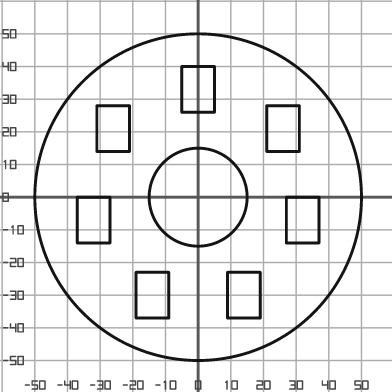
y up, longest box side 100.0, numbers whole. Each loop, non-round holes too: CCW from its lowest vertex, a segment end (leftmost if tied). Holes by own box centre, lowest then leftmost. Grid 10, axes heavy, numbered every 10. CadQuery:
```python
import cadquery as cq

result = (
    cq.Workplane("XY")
    .moveTo(0.0, 0.0)
    .circle(50.0)
    .moveTo(-19.0, -37.0)
    .lineTo(-9.0, -37.0)
    .lineTo(-9.0, -23.0)
    .lineTo(-19.0, -23.0)
    .close()
    .moveTo(9.0, -37.0)
    .lineTo(19.0, -37.0)
    .lineTo(19.0, -23.0)
    .lineTo(9.0, -23.0)
    .close()
    .moveTo(-37.0, -14.0)
    .lineTo(-27.0, -14.0)
    .lineTo(-27.0, 0.0)
    .lineTo(-37.0, 0.0)
    .close()
    .moveTo(27.0, -14.0)
    .lineTo(37.0, -14.0)
    .lineTo(37.0, 0.0)
    .lineTo(27.0, 0.0)
    .close()
    .moveTo(0.0, 0.0)
    .circle(15.0)
    .moveTo(-31.0, 14.0)
    .lineTo(-21.0, 14.0)
    .lineTo(-21.0, 28.0)
    .lineTo(-31.0, 28.0)
    .close()
    .moveTo(21.0, 14.0)
    .lineTo(31.0, 14.0)
    .lineTo(31.0, 28.0)
    .lineTo(21.0, 28.0)
    .close()
    .moveTo(-5.0, 26.0)
    .lineTo(5.0, 26.0)
    .lineTo(5.0, 40.0)
    .lineTo(-5.0, 40.0)
    .close()
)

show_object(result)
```